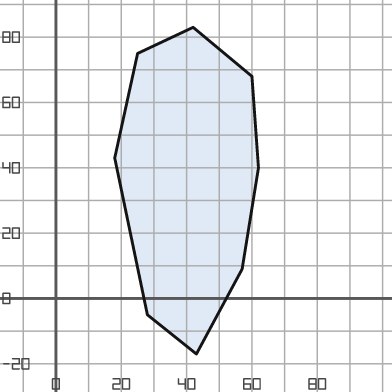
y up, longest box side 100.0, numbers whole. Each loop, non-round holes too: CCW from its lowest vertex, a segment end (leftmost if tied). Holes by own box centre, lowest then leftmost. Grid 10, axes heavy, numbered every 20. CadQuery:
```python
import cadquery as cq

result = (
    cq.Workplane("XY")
    .moveTo(43.0, -17.0)
    .lineTo(57.0, 9.0)
    .lineTo(62.0, 40.0)
    .lineTo(60.0, 68.0)
    .lineTo(42.0, 83.0)
    .lineTo(25.0, 75.0)
    .lineTo(18.0, 43.0)
    .lineTo(28.0, -5.0)
    .close()
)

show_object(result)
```